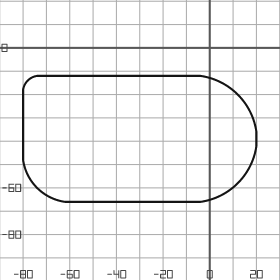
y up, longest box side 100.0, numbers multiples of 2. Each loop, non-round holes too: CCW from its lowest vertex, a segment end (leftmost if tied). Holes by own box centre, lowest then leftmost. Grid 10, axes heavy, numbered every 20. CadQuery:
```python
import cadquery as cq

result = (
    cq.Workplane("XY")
    .moveTo(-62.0, -66.0)
    .lineTo(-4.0, -66.0)
    .threePointArc((12.0, -58.0), (20.0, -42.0))
    .lineTo(20.0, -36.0)
    .threePointArc((12.0, -20.0), (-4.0, -12.0))
    .lineTo(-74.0, -12.0)
    .threePointArc((-78.0, -14.0), (-80.0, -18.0))
    .lineTo(-80.0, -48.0)
    .threePointArc((-74.0, -60.0), (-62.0, -66.0))
    .close()
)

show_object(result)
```